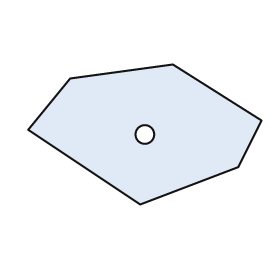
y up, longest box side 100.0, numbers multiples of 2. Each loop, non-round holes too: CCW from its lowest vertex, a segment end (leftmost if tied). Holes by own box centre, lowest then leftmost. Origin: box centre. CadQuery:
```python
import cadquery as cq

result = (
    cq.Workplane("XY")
    .moveTo(-2.0, -30.0)
    .lineTo(40.0, -14.0)
    .lineTo(50.0, 6.0)
    .lineTo(12.0, 30.0)
    .lineTo(-32.0, 24.0)
    .lineTo(-50.0, 2.0)
    .close()
    .moveTo(0.0, 0.0)
    .circle(4.0)
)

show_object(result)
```